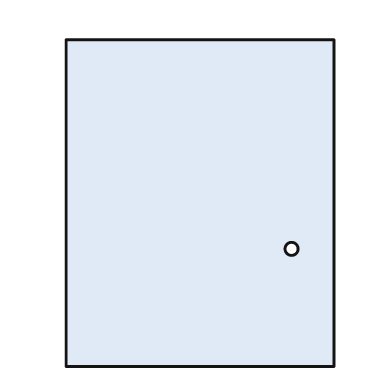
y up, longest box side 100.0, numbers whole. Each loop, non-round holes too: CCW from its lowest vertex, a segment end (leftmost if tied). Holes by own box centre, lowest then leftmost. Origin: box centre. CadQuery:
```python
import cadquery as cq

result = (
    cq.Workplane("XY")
    .moveTo(-41.0, -50.0)
    .lineTo(41.0, -50.0)
    .lineTo(41.0, 50.0)
    .lineTo(-41.0, 50.0)
    .close()
    .moveTo(28.0, -14.0)
    .circle(2.0)
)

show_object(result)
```